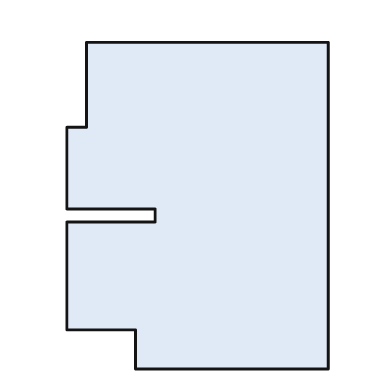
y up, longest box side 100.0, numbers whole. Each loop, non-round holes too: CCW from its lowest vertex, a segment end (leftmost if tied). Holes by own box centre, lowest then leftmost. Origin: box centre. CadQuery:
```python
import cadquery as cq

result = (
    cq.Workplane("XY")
    .moveTo(-19.0, -50.0)
    .lineTo(40.0, -50.0)
    .lineTo(40.0, 50.0)
    .lineTo(-34.0, 50.0)
    .lineTo(-34.0, 24.0)
    .lineTo(-40.0, 24.0)
    .lineTo(-40.0, -1.0)
    .lineTo(-13.0, -1.0)
    .lineTo(-13.0, -5.0)
    .lineTo(-40.0, -5.0)
    .lineTo(-40.0, -38.0)
    .lineTo(-19.0, -38.0)
    .close()
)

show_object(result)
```